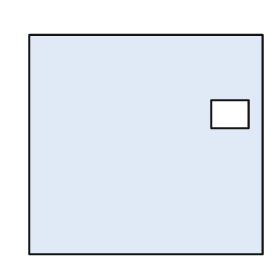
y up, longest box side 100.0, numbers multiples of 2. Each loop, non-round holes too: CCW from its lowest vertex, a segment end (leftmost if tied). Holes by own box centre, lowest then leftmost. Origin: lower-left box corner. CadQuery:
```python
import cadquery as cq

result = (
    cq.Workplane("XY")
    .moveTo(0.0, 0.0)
    .lineTo(100.0, 0.0)
    .lineTo(100.0, 94.0)
    .lineTo(0.0, 94.0)
    .close()
    .moveTo(78.0, 54.0)
    .lineTo(94.0, 54.0)
    .lineTo(94.0, 66.0)
    .lineTo(78.0, 66.0)
    .close()
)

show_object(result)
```